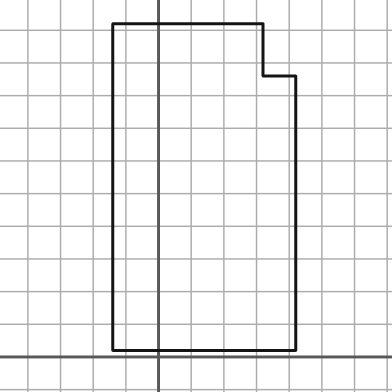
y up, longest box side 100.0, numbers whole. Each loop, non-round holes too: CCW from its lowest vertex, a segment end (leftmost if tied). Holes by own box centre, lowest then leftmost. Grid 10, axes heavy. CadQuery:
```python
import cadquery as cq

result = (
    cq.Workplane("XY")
    .moveTo(-14.0, 2.0)
    .lineTo(42.0, 2.0)
    .lineTo(42.0, 86.0)
    .lineTo(32.0, 86.0)
    .lineTo(32.0, 102.0)
    .lineTo(-14.0, 102.0)
    .close()
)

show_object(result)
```